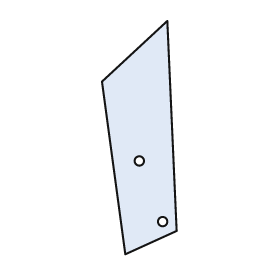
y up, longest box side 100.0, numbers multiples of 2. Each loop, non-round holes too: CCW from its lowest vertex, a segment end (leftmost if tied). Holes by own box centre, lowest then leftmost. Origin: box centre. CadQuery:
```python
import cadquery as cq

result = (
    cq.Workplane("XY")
    .moveTo(-6.0, -50.0)
    .lineTo(16.0, -40.0)
    .lineTo(12.0, 50.0)
    .lineTo(-16.0, 24.0)
    .close()
    .moveTo(10.0, -36.0)
    .circle(2.0)
    .moveTo(0.0, -10.0)
    .circle(2.0)
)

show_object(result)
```